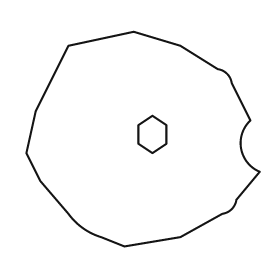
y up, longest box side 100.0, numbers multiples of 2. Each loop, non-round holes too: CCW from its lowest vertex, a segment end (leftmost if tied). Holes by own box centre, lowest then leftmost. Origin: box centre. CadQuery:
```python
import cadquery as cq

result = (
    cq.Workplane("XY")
    .moveTo(-8.0, -46.0)
    .lineTo(16.0, -42.0)
    .lineTo(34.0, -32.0)
    .threePointArc((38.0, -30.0), (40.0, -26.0))
    .lineTo(50.0, -14.0)
    .threePointArc((42.0, -4.0), (46.0, 8.0))
    .lineTo(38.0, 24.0)
    .threePointArc((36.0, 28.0), (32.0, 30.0))
    .lineTo(16.0, 40.0)
    .lineTo(-4.0, 46.0)
    .lineTo(-32.0, 40.0)
    .lineTo(-46.0, 12.0)
    .lineTo(-50.0, -6.0)
    .lineTo(-44.0, -18.0)
    .lineTo(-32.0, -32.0)
    .threePointArc((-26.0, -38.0), (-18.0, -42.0))
    .close()
    .moveTo(4.0, -6.0)
    .lineTo(10.0, -2.0)
    .lineTo(10.0, 6.0)
    .lineTo(4.0, 10.0)
    .lineTo(-2.0, 6.0)
    .lineTo(-2.0, -2.0)
    .close()
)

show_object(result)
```